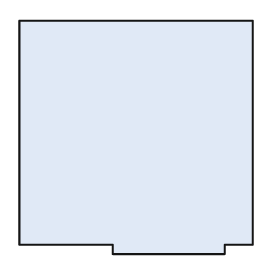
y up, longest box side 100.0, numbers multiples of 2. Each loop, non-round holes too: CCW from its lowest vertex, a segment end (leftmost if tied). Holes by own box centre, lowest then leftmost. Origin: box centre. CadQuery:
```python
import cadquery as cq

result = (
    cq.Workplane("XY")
    .moveTo(-10.0, -50.0)
    .lineTo(38.0, -50.0)
    .lineTo(38.0, -46.0)
    .lineTo(50.0, -46.0)
    .lineTo(50.0, 50.0)
    .lineTo(-50.0, 50.0)
    .lineTo(-50.0, -46.0)
    .lineTo(-10.0, -46.0)
    .close()
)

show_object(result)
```